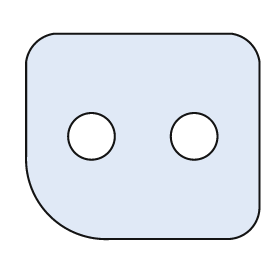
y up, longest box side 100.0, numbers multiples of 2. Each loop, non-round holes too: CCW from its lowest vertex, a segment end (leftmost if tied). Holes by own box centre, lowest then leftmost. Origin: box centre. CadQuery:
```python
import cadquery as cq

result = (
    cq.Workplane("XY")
    .moveTo(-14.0, -44.0)
    .lineTo(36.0, -44.0)
    .threePointArc((46.0, -40.0), (50.0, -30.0))
    .lineTo(50.0, 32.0)
    .threePointArc((46.0, 40.0), (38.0, 44.0))
    .lineTo(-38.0, 44.0)
    .threePointArc((-46.0, 40.0), (-50.0, 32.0))
    .lineTo(-50.0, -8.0)
    .threePointArc((-40.0, -34.0), (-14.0, -44.0))
    .close()
    .moveTo(-22.0, 0.0)
    .circle(10.0)
    .moveTo(22.0, 0.0)
    .circle(10.0)
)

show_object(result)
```